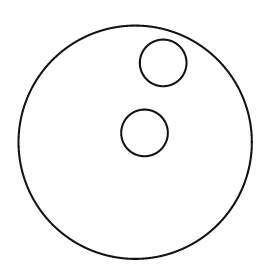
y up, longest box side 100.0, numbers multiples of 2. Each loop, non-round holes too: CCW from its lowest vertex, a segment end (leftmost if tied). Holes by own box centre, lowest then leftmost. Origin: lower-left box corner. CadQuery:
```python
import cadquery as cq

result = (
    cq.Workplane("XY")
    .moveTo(50.0, 50.0)
    .circle(50.0)
    .moveTo(54.0, 54.0)
    .circle(10.0)
    .moveTo(62.0, 84.0)
    .circle(10.0)
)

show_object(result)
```